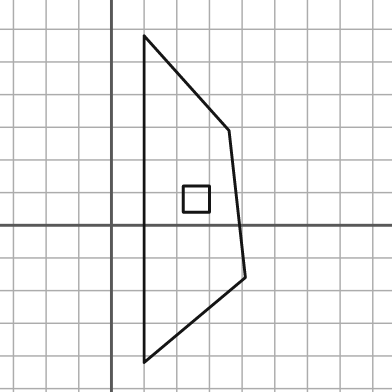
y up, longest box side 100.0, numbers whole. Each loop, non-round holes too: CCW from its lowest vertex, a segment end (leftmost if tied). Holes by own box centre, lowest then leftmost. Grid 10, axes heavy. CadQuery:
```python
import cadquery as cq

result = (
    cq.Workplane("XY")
    .moveTo(10.0, -42.0)
    .lineTo(41.0, -16.0)
    .lineTo(36.0, 29.0)
    .lineTo(10.0, 58.0)
    .close()
    .moveTo(22.0, 4.0)
    .lineTo(30.0, 4.0)
    .lineTo(30.0, 12.0)
    .lineTo(22.0, 12.0)
    .close()
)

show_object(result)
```